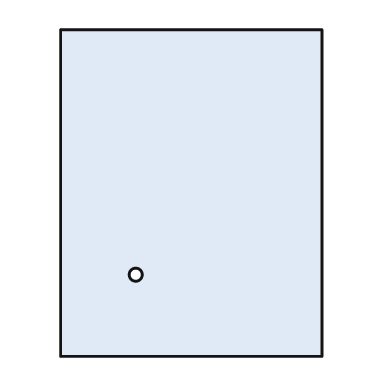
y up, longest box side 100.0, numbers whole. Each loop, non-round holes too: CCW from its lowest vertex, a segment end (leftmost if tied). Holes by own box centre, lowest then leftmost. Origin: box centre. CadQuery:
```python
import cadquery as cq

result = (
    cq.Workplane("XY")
    .moveTo(-40.0, -50.0)
    .lineTo(40.0, -50.0)
    .lineTo(40.0, 50.0)
    .lineTo(-40.0, 50.0)
    .close()
    .moveTo(-17.0, -25.0)
    .circle(2.0)
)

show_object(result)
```